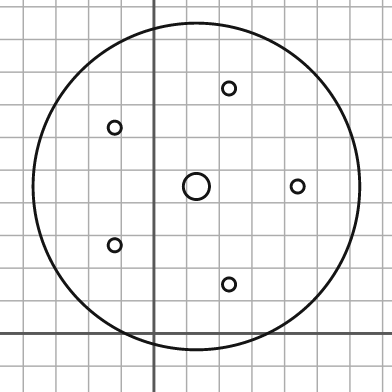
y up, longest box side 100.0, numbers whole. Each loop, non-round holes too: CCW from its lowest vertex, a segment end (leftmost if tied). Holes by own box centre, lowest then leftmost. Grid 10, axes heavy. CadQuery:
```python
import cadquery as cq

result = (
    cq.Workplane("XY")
    .moveTo(13.0, 45.0)
    .circle(50.0)
    .moveTo(23.0, 15.0)
    .circle(2.0)
    .moveTo(-12.0, 27.0)
    .circle(2.0)
    .moveTo(13.0, 45.0)
    .circle(4.0)
    .moveTo(44.0, 45.0)
    .circle(2.0)
    .moveTo(-12.0, 63.0)
    .circle(2.0)
    .moveTo(23.0, 75.0)
    .circle(2.0)
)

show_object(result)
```